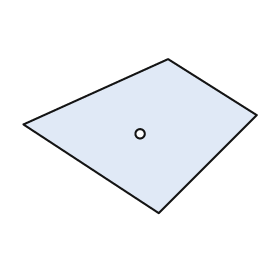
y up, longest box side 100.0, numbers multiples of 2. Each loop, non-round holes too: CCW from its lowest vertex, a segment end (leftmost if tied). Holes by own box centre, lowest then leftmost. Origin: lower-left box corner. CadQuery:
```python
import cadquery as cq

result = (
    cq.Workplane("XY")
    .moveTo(58.0, 0.0)
    .lineTo(100.0, 42.0)
    .lineTo(62.0, 66.0)
    .lineTo(0.0, 38.0)
    .close()
    .moveTo(50.0, 34.0)
    .circle(2.0)
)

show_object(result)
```